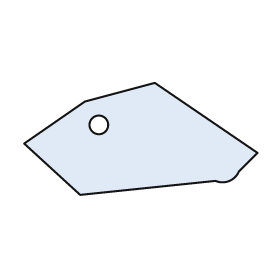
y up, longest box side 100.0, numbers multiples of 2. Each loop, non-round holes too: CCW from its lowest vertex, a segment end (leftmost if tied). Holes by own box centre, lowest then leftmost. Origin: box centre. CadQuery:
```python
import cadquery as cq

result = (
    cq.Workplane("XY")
    .moveTo(-26.0, -24.0)
    .lineTo(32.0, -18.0)
    .threePointArc((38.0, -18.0), (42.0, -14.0))
    .lineTo(50.0, -6.0)
    .lineTo(6.0, 24.0)
    .lineTo(-24.0, 16.0)
    .lineTo(-50.0, -2.0)
    .close()
    .moveTo(-18.0, 6.0)
    .circle(4.0)
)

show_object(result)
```